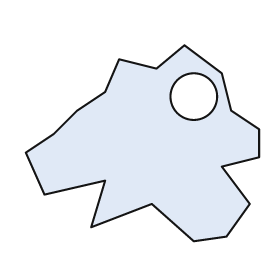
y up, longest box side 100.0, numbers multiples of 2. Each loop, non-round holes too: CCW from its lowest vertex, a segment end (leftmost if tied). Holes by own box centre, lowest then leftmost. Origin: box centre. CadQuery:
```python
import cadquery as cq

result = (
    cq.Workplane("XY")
    .moveTo(22.0, -42.0)
    .lineTo(36.0, -40.0)
    .lineTo(46.0, -26.0)
    .lineTo(34.0, -10.0)
    .lineTo(50.0, -6.0)
    .lineTo(50.0, 6.0)
    .lineTo(38.0, 14.0)
    .lineTo(34.0, 30.0)
    .lineTo(18.0, 42.0)
    .lineTo(6.0, 32.0)
    .lineTo(-10.0, 36.0)
    .lineTo(-16.0, 22.0)
    .lineTo(-28.0, 14.0)
    .lineTo(-38.0, 4.0)
    .lineTo(-50.0, -4.0)
    .lineTo(-42.0, -22.0)
    .lineTo(-16.0, -16.0)
    .lineTo(-22.0, -36.0)
    .lineTo(4.0, -26.0)
    .close()
    .moveTo(22.0, 20.0)
    .circle(10.0)
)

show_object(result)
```